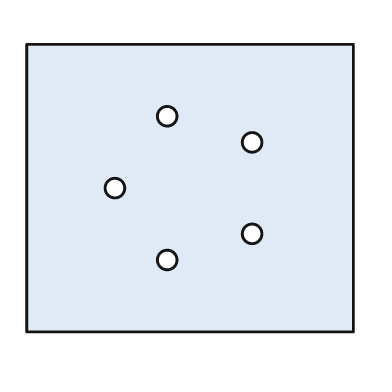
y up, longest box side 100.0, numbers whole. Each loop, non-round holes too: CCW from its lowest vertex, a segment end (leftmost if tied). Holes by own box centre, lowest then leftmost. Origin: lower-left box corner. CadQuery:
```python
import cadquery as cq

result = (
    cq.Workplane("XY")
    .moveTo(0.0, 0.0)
    .lineTo(100.0, 0.0)
    .lineTo(100.0, 88.0)
    .lineTo(0.0, 88.0)
    .close()
    .moveTo(43.0, 22.0)
    .circle(3.0)
    .moveTo(69.0, 30.0)
    .circle(3.0)
    .moveTo(27.0, 44.0)
    .circle(3.0)
    .moveTo(69.0, 58.0)
    .circle(3.0)
    .moveTo(43.0, 66.0)
    .circle(3.0)
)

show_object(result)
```